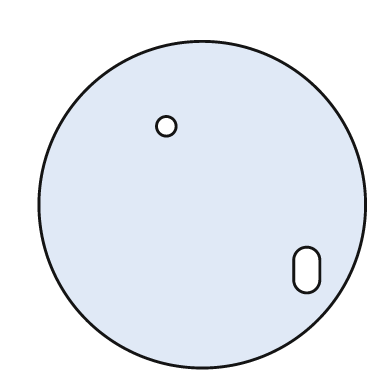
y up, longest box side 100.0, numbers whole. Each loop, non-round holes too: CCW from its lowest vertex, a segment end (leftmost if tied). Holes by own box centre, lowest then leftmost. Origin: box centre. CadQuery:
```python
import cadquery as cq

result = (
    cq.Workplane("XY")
    .moveTo(0.0, 0.0)
    .circle(50.0)
    .moveTo(28.0, -23.0)
    .threePointArc((32.0, -27.0), (36.0, -23.0))
    .lineTo(36.0, -17.0)
    .threePointArc((32.0, -13.0), (28.0, -17.0))
    .close()
    .moveTo(-11.0, 24.0)
    .circle(3.0)
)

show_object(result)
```